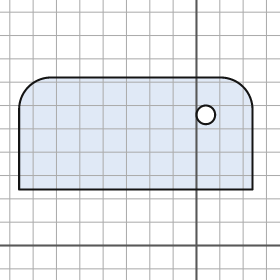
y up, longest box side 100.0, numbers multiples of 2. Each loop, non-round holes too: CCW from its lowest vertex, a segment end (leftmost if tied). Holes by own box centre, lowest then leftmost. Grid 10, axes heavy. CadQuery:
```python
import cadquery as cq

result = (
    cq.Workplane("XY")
    .moveTo(-76.0, 24.0)
    .lineTo(24.0, 24.0)
    .lineTo(24.0, 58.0)
    .threePointArc((20.0, 68.0), (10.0, 72.0))
    .lineTo(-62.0, 72.0)
    .threePointArc((-72.0, 68.0), (-76.0, 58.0))
    .close()
    .moveTo(4.0, 56.0)
    .circle(4.0)
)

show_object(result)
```